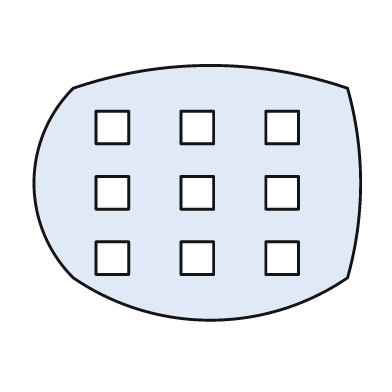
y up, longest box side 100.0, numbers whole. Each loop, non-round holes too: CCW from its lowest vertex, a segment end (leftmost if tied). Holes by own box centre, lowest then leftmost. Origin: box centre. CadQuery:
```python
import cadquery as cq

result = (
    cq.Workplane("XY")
    .moveTo(-38.0, -26.0)
    .threePointArc((4.0, -39.0), (46.0, -26.0))
    .threePointArc((50.0, 3.0), (46.0, 32.0))
    .threePointArc((4.0, 39.0), (-38.0, 32.0))
    .threePointArc((-50.0, 3.0), (-38.0, -26.0))
    .close()
    .moveTo(-31.0, -25.0)
    .lineTo(-21.0, -25.0)
    .lineTo(-21.0, -15.0)
    .lineTo(-31.0, -15.0)
    .close()
    .moveTo(-5.0, -25.0)
    .lineTo(5.0, -25.0)
    .lineTo(5.0, -15.0)
    .lineTo(-5.0, -15.0)
    .close()
    .moveTo(21.0, -25.0)
    .lineTo(31.0, -25.0)
    .lineTo(31.0, -15.0)
    .lineTo(21.0, -15.0)
    .close()
    .moveTo(-31.0, -5.0)
    .lineTo(-21.0, -5.0)
    .lineTo(-21.0, 5.0)
    .lineTo(-31.0, 5.0)
    .close()
    .moveTo(-5.0, -5.0)
    .lineTo(5.0, -5.0)
    .lineTo(5.0, 5.0)
    .lineTo(-5.0, 5.0)
    .close()
    .moveTo(21.0, -5.0)
    .lineTo(31.0, -5.0)
    .lineTo(31.0, 5.0)
    .lineTo(21.0, 5.0)
    .close()
    .moveTo(-31.0, 15.0)
    .lineTo(-21.0, 15.0)
    .lineTo(-21.0, 25.0)
    .lineTo(-31.0, 25.0)
    .close()
    .moveTo(-5.0, 15.0)
    .lineTo(5.0, 15.0)
    .lineTo(5.0, 25.0)
    .lineTo(-5.0, 25.0)
    .close()
    .moveTo(21.0, 15.0)
    .lineTo(31.0, 15.0)
    .lineTo(31.0, 25.0)
    .lineTo(21.0, 25.0)
    .close()
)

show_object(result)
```